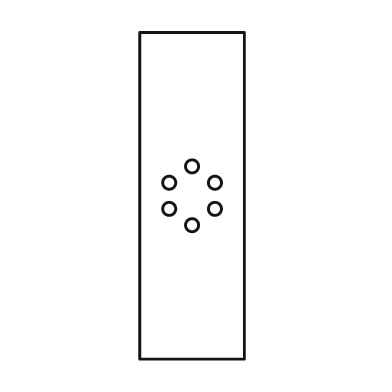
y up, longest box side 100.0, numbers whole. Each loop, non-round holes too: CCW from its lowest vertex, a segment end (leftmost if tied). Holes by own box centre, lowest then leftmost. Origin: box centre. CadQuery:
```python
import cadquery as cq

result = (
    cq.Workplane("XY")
    .moveTo(-16.0, -50.0)
    .lineTo(16.0, -50.0)
    .lineTo(16.0, 50.0)
    .lineTo(-16.0, 50.0)
    .close()
    .moveTo(0.0, -9.0)
    .circle(2.0)
    .moveTo(-7.0, -4.0)
    .circle(2.0)
    .moveTo(7.0, -4.0)
    .circle(2.0)
    .moveTo(-7.0, 4.0)
    .circle(2.0)
    .moveTo(7.0, 4.0)
    .circle(2.0)
    .moveTo(0.0, 9.0)
    .circle(2.0)
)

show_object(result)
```